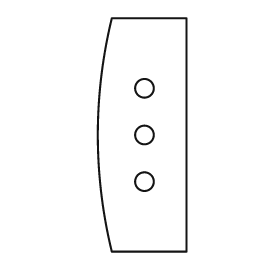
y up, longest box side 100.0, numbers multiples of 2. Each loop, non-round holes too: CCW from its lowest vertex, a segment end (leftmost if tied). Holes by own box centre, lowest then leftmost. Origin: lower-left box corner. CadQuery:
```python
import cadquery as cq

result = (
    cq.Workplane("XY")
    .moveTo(6.0, 0.0)
    .lineTo(38.0, 0.0)
    .lineTo(38.0, 100.0)
    .lineTo(6.0, 100.0)
    .threePointArc((0.0, 50.0), (6.0, 0.0))
    .close()
    .moveTo(20.0, 30.0)
    .circle(4.0)
    .moveTo(20.0, 50.0)
    .circle(4.0)
    .moveTo(20.0, 70.0)
    .circle(4.0)
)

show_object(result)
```